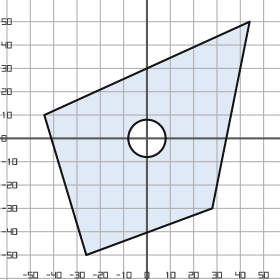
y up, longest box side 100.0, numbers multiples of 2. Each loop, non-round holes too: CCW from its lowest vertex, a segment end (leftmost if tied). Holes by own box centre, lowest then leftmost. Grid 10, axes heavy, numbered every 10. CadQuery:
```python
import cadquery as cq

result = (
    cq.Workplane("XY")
    .moveTo(-26.0, -50.0)
    .lineTo(28.0, -30.0)
    .lineTo(44.0, 50.0)
    .lineTo(-44.0, 10.0)
    .close()
    .moveTo(0.0, 0.0)
    .circle(8.0)
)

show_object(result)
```